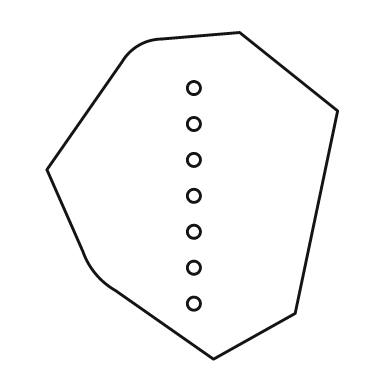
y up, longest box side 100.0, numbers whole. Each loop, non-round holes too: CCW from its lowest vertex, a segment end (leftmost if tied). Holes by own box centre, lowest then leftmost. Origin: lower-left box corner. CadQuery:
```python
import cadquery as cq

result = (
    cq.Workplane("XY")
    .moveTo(51.0, 0.0)
    .lineTo(76.0, 14.0)
    .lineTo(89.0, 76.0)
    .lineTo(59.0, 100.0)
    .lineTo(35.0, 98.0)
    .threePointArc((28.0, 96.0), (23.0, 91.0))
    .lineTo(0.0, 58.0)
    .lineTo(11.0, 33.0)
    .threePointArc((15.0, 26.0), (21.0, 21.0))
    .close()
    .moveTo(45.0, 17.0)
    .circle(2.0)
    .moveTo(45.0, 28.0)
    .circle(2.0)
    .moveTo(45.0, 39.0)
    .circle(2.0)
    .moveTo(45.0, 50.0)
    .circle(2.0)
    .moveTo(45.0, 61.0)
    .circle(2.0)
    .moveTo(45.0, 72.0)
    .circle(2.0)
    .moveTo(45.0, 83.0)
    .circle(2.0)
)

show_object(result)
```